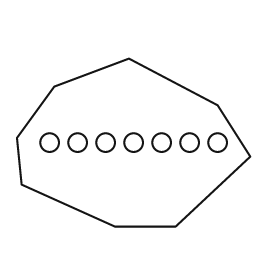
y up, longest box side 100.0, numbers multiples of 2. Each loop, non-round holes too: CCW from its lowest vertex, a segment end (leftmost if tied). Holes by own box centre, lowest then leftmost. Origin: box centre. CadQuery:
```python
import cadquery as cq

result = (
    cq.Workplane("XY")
    .moveTo(-8.0, -36.0)
    .lineTo(18.0, -36.0)
    .lineTo(50.0, -6.0)
    .lineTo(36.0, 16.0)
    .lineTo(-2.0, 36.0)
    .lineTo(-34.0, 24.0)
    .lineTo(-50.0, 2.0)
    .lineTo(-48.0, -18.0)
    .close()
    .moveTo(-36.0, 0.0)
    .circle(4.0)
    .moveTo(-24.0, 0.0)
    .circle(4.0)
    .moveTo(-12.0, 0.0)
    .circle(4.0)
    .moveTo(0.0, 0.0)
    .circle(4.0)
    .moveTo(12.0, 0.0)
    .circle(4.0)
    .moveTo(24.0, 0.0)
    .circle(4.0)
    .moveTo(36.0, 0.0)
    .circle(4.0)
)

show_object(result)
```